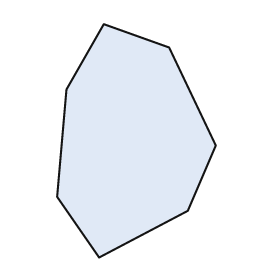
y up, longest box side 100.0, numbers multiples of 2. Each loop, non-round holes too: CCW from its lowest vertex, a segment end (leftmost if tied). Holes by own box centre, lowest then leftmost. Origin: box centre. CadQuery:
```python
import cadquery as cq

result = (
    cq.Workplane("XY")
    .moveTo(-16.0, -50.0)
    .lineTo(22.0, -30.0)
    .lineTo(34.0, -2.0)
    .lineTo(14.0, 40.0)
    .lineTo(-14.0, 50.0)
    .lineTo(-30.0, 22.0)
    .lineTo(-34.0, -24.0)
    .close()
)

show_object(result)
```